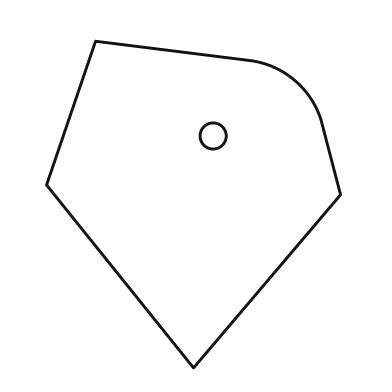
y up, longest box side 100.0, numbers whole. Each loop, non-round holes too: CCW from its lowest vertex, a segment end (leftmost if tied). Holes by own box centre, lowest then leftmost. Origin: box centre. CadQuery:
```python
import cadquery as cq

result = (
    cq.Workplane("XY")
    .moveTo(0.0, -50.0)
    .lineTo(45.0, 3.0)
    .lineTo(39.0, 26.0)
    .threePointArc((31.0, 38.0), (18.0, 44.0))
    .lineTo(-30.0, 50.0)
    .lineTo(-45.0, 6.0)
    .close()
    .moveTo(6.0, 21.0)
    .circle(4.0)
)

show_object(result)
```